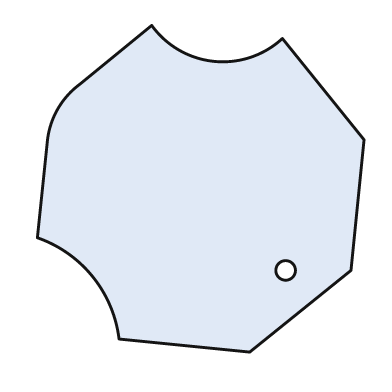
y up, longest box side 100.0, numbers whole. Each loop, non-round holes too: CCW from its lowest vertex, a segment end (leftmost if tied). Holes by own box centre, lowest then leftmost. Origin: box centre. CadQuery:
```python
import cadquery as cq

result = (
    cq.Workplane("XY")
    .moveTo(15.0, -50.0)
    .lineTo(46.0, -25.0)
    .lineTo(50.0, 15.0)
    .lineTo(25.0, 46.0)
    .threePointArc((4.0, 39.0), (-15.0, 50.0))
    .lineTo(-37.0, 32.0)
    .threePointArc((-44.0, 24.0), (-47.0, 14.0))
    .lineTo(-50.0, -15.0)
    .threePointArc((-33.0, -27.0), (-25.0, -46.0))
    .close()
    .moveTo(26.0, -25.0)
    .circle(3.0)
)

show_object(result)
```